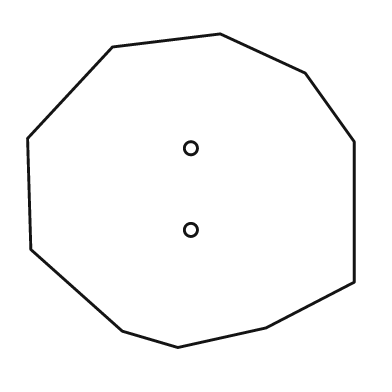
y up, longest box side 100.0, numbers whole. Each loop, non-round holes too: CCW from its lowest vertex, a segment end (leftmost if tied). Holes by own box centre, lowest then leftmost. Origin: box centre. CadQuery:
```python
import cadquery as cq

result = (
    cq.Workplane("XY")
    .moveTo(-4.0, -48.0)
    .lineTo(23.0, -42.0)
    .lineTo(50.0, -28.0)
    .lineTo(50.0, 15.0)
    .lineTo(35.0, 36.0)
    .lineTo(9.0, 48.0)
    .lineTo(-24.0, 44.0)
    .lineTo(-50.0, 16.0)
    .lineTo(-49.0, -18.0)
    .lineTo(-21.0, -43.0)
    .close()
    .moveTo(0.0, -12.0)
    .circle(2.0)
    .moveTo(0.0, 13.0)
    .circle(2.0)
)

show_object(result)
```